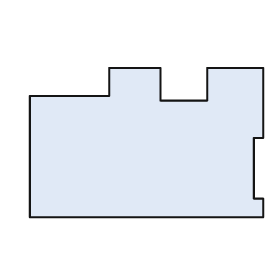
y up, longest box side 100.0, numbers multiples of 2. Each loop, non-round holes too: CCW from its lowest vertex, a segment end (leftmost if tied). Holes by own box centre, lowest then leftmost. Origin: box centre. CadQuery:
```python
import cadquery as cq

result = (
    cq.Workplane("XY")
    .moveTo(-50.0, -32.0)
    .lineTo(50.0, -32.0)
    .lineTo(50.0, -24.0)
    .lineTo(46.0, -24.0)
    .lineTo(46.0, 2.0)
    .lineTo(50.0, 2.0)
    .lineTo(50.0, 32.0)
    .lineTo(26.0, 32.0)
    .lineTo(26.0, 18.0)
    .lineTo(6.0, 18.0)
    .lineTo(6.0, 32.0)
    .lineTo(-16.0, 32.0)
    .lineTo(-16.0, 20.0)
    .lineTo(-50.0, 20.0)
    .close()
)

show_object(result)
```